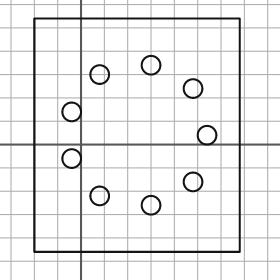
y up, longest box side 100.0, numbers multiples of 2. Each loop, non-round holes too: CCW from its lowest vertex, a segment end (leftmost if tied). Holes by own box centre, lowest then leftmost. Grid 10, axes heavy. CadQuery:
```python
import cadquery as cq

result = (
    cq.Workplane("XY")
    .moveTo(-20.0, -46.0)
    .lineTo(68.0, -46.0)
    .lineTo(68.0, 54.0)
    .lineTo(-20.0, 54.0)
    .close()
    .moveTo(30.0, -26.0)
    .circle(4.0)
    .moveTo(8.0, -22.0)
    .circle(4.0)
    .moveTo(48.0, -16.0)
    .circle(4.0)
    .moveTo(-4.0, -6.0)
    .circle(4.0)
    .moveTo(54.0, 4.0)
    .circle(4.0)
    .moveTo(-4.0, 14.0)
    .circle(4.0)
    .moveTo(48.0, 24.0)
    .circle(4.0)
    .moveTo(8.0, 30.0)
    .circle(4.0)
    .moveTo(30.0, 34.0)
    .circle(4.0)
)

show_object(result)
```